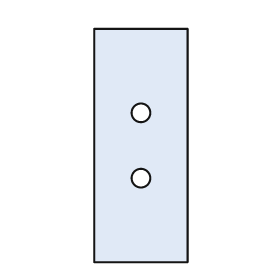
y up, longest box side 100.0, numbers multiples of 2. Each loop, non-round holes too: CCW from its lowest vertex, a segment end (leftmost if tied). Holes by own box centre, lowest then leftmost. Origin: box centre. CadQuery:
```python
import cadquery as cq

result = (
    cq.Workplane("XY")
    .moveTo(-20.0, -50.0)
    .lineTo(20.0, -50.0)
    .lineTo(20.0, 50.0)
    .lineTo(-20.0, 50.0)
    .close()
    .moveTo(0.0, -14.0)
    .circle(4.0)
    .moveTo(0.0, 14.0)
    .circle(4.0)
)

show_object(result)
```